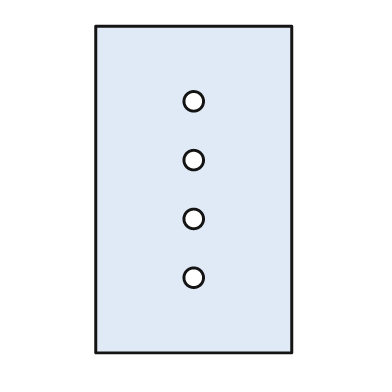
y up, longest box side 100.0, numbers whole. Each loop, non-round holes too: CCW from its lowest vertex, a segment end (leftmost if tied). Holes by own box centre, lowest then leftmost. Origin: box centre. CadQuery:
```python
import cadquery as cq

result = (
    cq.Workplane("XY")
    .moveTo(-30.0, -50.0)
    .lineTo(30.0, -50.0)
    .lineTo(30.0, 50.0)
    .lineTo(-30.0, 50.0)
    .close()
    .moveTo(0.0, -27.0)
    .circle(3.0)
    .moveTo(0.0, -9.0)
    .circle(3.0)
    .moveTo(0.0, 9.0)
    .circle(3.0)
    .moveTo(0.0, 27.0)
    .circle(3.0)
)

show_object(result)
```